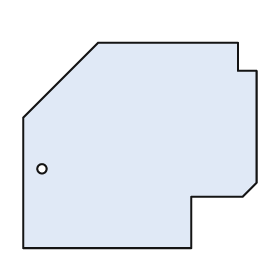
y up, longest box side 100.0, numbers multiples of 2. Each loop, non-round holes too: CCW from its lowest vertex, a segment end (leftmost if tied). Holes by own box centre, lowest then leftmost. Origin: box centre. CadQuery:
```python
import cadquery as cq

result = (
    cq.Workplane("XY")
    .moveTo(-50.0, -44.0)
    .lineTo(22.0, -44.0)
    .lineTo(22.0, -22.0)
    .lineTo(44.0, -22.0)
    .lineTo(50.0, -16.0)
    .lineTo(50.0, 32.0)
    .lineTo(42.0, 32.0)
    .lineTo(42.0, 44.0)
    .lineTo(-18.0, 44.0)
    .lineTo(-50.0, 12.0)
    .close()
    .moveTo(-42.0, -10.0)
    .circle(2.0)
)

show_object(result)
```